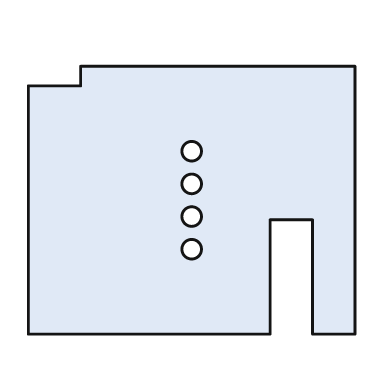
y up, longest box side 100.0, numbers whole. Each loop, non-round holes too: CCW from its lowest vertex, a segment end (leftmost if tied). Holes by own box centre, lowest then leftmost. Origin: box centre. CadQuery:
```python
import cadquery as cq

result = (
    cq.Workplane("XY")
    .moveTo(-50.0, -41.0)
    .lineTo(24.0, -41.0)
    .lineTo(24.0, -6.0)
    .lineTo(37.0, -6.0)
    .lineTo(37.0, -41.0)
    .lineTo(50.0, -41.0)
    .lineTo(50.0, 41.0)
    .lineTo(-34.0, 41.0)
    .lineTo(-34.0, 35.0)
    .lineTo(-50.0, 35.0)
    .close()
    .moveTo(0.0, -15.0)
    .circle(3.0)
    .moveTo(0.0, -5.0)
    .circle(3.0)
    .moveTo(0.0, 5.0)
    .circle(3.0)
    .moveTo(0.0, 15.0)
    .circle(3.0)
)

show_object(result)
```